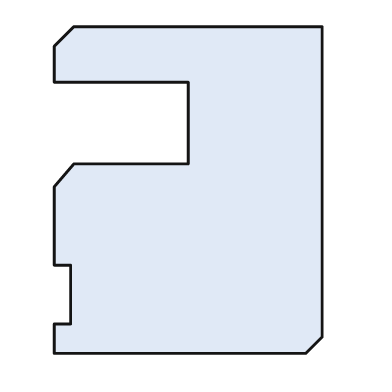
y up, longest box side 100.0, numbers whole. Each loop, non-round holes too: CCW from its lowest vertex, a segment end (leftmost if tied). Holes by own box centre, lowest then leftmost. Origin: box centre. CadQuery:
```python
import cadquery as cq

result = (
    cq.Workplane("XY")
    .moveTo(-41.0, -50.0)
    .lineTo(36.0, -50.0)
    .lineTo(41.0, -45.0)
    .lineTo(41.0, 50.0)
    .lineTo(-35.0, 50.0)
    .lineTo(-41.0, 44.0)
    .lineTo(-41.0, 33.0)
    .lineTo(0.0, 33.0)
    .lineTo(0.0, 8.0)
    .lineTo(-35.0, 8.0)
    .lineTo(-41.0, 1.0)
    .lineTo(-41.0, -23.0)
    .lineTo(-36.0, -23.0)
    .lineTo(-36.0, -41.0)
    .lineTo(-41.0, -41.0)
    .close()
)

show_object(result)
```